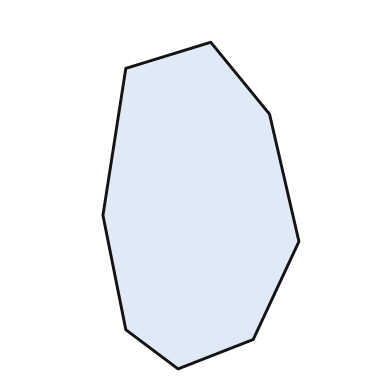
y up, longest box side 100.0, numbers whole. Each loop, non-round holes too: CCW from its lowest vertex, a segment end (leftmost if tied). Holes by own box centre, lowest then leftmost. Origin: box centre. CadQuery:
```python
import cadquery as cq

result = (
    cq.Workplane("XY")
    .moveTo(-7.0, -50.0)
    .lineTo(16.0, -41.0)
    .lineTo(30.0, -11.0)
    .lineTo(21.0, 28.0)
    .lineTo(3.0, 50.0)
    .lineTo(-23.0, 42.0)
    .lineTo(-30.0, -3.0)
    .lineTo(-23.0, -38.0)
    .close()
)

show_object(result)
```